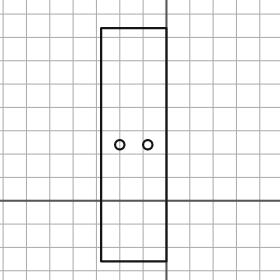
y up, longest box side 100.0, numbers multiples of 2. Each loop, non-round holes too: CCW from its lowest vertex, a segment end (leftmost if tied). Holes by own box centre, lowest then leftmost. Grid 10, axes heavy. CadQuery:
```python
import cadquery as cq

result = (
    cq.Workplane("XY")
    .moveTo(-28.0, -26.0)
    .lineTo(0.0, -26.0)
    .lineTo(0.0, 74.0)
    .lineTo(-28.0, 74.0)
    .close()
    .moveTo(-20.0, 24.0)
    .circle(2.0)
    .moveTo(-8.0, 24.0)
    .circle(2.0)
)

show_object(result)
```